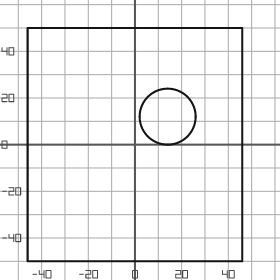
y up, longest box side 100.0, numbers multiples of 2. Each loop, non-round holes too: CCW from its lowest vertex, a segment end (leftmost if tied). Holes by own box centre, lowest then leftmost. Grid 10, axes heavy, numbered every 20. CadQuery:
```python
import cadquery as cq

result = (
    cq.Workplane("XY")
    .moveTo(-46.0, -50.0)
    .lineTo(46.0, -50.0)
    .lineTo(46.0, 50.0)
    .lineTo(-46.0, 50.0)
    .close()
    .moveTo(14.0, 12.0)
    .circle(12.0)
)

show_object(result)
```